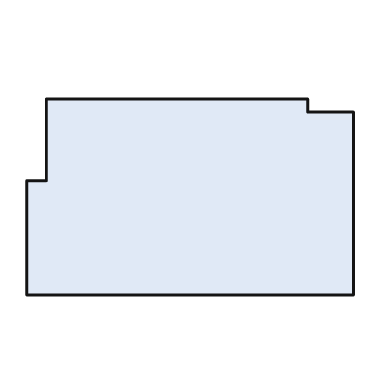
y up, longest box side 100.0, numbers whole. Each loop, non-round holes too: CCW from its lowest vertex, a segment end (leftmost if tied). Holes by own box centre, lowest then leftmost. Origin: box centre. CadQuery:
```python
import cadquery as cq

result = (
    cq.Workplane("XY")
    .moveTo(-50.0, -30.0)
    .lineTo(50.0, -30.0)
    .lineTo(50.0, 26.0)
    .lineTo(36.0, 26.0)
    .lineTo(36.0, 30.0)
    .lineTo(-44.0, 30.0)
    .lineTo(-44.0, 5.0)
    .lineTo(-50.0, 5.0)
    .close()
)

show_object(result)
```